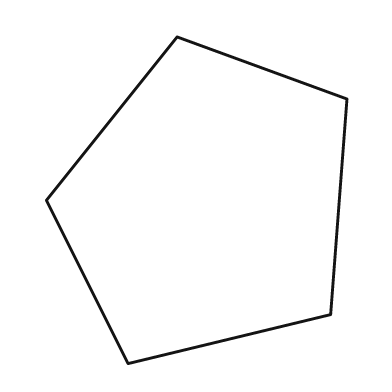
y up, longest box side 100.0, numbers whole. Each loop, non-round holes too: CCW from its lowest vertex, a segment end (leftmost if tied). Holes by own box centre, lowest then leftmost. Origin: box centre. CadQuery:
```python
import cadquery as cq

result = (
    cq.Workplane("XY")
    .moveTo(-21.0, -50.0)
    .lineTo(41.0, -35.0)
    .lineTo(46.0, 31.0)
    .lineTo(-6.0, 50.0)
    .lineTo(-46.0, 0.0)
    .close()
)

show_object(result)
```